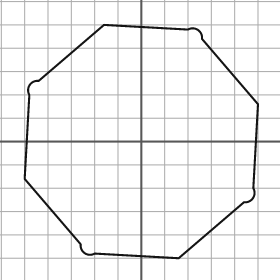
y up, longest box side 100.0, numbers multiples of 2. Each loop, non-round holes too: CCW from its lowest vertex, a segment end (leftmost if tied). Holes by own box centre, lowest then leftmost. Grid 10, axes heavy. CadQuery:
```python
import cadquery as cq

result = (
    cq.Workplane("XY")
    .moveTo(16.0, -50.0)
    .lineTo(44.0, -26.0)
    .threePointArc((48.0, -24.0), (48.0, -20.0))
    .lineTo(50.0, 16.0)
    .lineTo(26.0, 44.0)
    .threePointArc((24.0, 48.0), (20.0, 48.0))
    .lineTo(-16.0, 50.0)
    .lineTo(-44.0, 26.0)
    .threePointArc((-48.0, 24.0), (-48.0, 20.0))
    .lineTo(-50.0, -16.0)
    .lineTo(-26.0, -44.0)
    .threePointArc((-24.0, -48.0), (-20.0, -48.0))
    .close()
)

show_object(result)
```